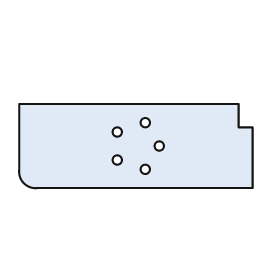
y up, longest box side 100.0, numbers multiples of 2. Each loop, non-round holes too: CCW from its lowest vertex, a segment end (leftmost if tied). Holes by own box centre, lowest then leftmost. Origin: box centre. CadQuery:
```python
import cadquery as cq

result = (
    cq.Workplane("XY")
    .moveTo(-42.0, -18.0)
    .lineTo(50.0, -18.0)
    .lineTo(50.0, 8.0)
    .lineTo(44.0, 8.0)
    .lineTo(44.0, 18.0)
    .lineTo(-50.0, 18.0)
    .lineTo(-50.0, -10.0)
    .threePointArc((-48.0, -16.0), (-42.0, -18.0))
    .close()
    .moveTo(4.0, -10.0)
    .circle(2.0)
    .moveTo(-8.0, -6.0)
    .circle(2.0)
    .moveTo(10.0, 0.0)
    .circle(2.0)
    .moveTo(-8.0, 6.0)
    .circle(2.0)
    .moveTo(4.0, 10.0)
    .circle(2.0)
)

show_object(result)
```